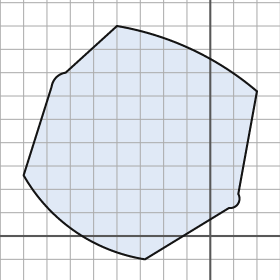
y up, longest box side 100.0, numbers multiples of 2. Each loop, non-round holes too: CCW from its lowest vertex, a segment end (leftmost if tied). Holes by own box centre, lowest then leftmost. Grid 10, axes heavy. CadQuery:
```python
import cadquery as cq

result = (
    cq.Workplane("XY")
    .moveTo(-28.0, -10.0)
    .lineTo(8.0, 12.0)
    .threePointArc((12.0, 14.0), (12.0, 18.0))
    .lineTo(20.0, 62.0)
    .threePointArc((-8.0, 80.0), (-40.0, 90.0))
    .lineTo(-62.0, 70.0)
    .threePointArc((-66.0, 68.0), (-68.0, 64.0))
    .lineTo(-80.0, 26.0)
    .threePointArc((-58.0, 2.0), (-28.0, -10.0))
    .close()
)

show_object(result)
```